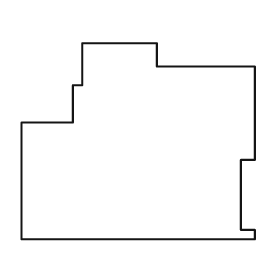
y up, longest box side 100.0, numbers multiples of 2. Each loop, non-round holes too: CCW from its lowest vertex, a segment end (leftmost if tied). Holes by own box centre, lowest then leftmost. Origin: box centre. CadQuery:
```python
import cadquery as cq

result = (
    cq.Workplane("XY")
    .moveTo(-50.0, -42.0)
    .lineTo(50.0, -42.0)
    .lineTo(50.0, -38.0)
    .lineTo(44.0, -38.0)
    .lineTo(44.0, -8.0)
    .lineTo(50.0, -8.0)
    .lineTo(50.0, 32.0)
    .lineTo(8.0, 32.0)
    .lineTo(8.0, 42.0)
    .lineTo(-24.0, 42.0)
    .lineTo(-24.0, 24.0)
    .lineTo(-28.0, 24.0)
    .lineTo(-28.0, 8.0)
    .lineTo(-50.0, 8.0)
    .close()
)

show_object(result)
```